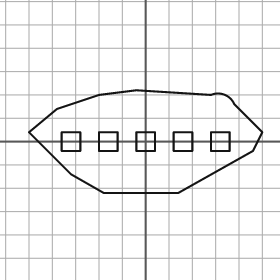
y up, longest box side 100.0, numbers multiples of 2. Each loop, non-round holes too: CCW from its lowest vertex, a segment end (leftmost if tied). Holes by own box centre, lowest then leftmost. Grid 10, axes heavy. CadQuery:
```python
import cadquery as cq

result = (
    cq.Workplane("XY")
    .moveTo(-18.0, -22.0)
    .lineTo(14.0, -22.0)
    .lineTo(46.0, -4.0)
    .lineTo(50.0, 4.0)
    .lineTo(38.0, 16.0)
    .threePointArc((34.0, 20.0), (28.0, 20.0))
    .lineTo(-4.0, 22.0)
    .lineTo(-20.0, 20.0)
    .lineTo(-38.0, 14.0)
    .lineTo(-50.0, 4.0)
    .lineTo(-32.0, -14.0)
    .close()
    .moveTo(-36.0, -4.0)
    .lineTo(-28.0, -4.0)
    .lineTo(-28.0, 4.0)
    .lineTo(-36.0, 4.0)
    .close()
    .moveTo(-20.0, -4.0)
    .lineTo(-12.0, -4.0)
    .lineTo(-12.0, 4.0)
    .lineTo(-20.0, 4.0)
    .close()
    .moveTo(-4.0, -4.0)
    .lineTo(4.0, -4.0)
    .lineTo(4.0, 4.0)
    .lineTo(-4.0, 4.0)
    .close()
    .moveTo(12.0, -4.0)
    .lineTo(20.0, -4.0)
    .lineTo(20.0, 4.0)
    .lineTo(12.0, 4.0)
    .close()
    .moveTo(28.0, -4.0)
    .lineTo(36.0, -4.0)
    .lineTo(36.0, 4.0)
    .lineTo(28.0, 4.0)
    .close()
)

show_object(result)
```